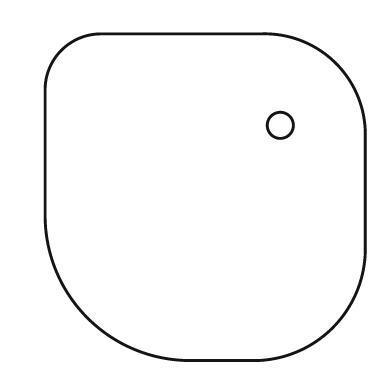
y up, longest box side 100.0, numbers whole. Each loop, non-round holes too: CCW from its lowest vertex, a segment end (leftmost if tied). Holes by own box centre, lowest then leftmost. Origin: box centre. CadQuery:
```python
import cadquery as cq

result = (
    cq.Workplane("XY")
    .moveTo(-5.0, -50.0)
    .lineTo(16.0, -50.0)
    .threePointArc((39.0, -40.0), (49.0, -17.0))
    .lineTo(49.0, 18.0)
    .threePointArc((40.0, 41.0), (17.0, 50.0))
    .lineTo(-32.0, 50.0)
    .threePointArc((-44.0, 45.0), (-49.0, 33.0))
    .lineTo(-49.0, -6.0)
    .threePointArc((-36.0, -37.0), (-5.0, -50.0))
    .close()
    .moveTo(23.0, 22.0)
    .circle(4.0)
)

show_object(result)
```